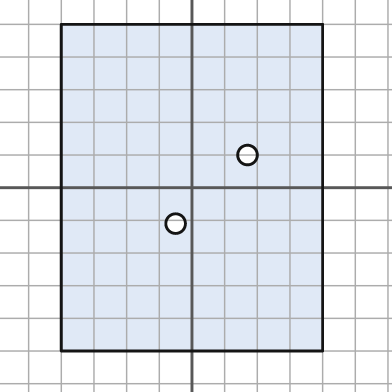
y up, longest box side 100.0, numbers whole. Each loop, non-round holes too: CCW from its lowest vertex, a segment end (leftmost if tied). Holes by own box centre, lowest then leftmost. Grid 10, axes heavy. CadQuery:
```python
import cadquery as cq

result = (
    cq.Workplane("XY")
    .moveTo(-40.0, -50.0)
    .lineTo(40.0, -50.0)
    .lineTo(40.0, 50.0)
    .lineTo(-40.0, 50.0)
    .close()
    .moveTo(-5.0, -11.0)
    .circle(3.0)
    .moveTo(17.0, 10.0)
    .circle(3.0)
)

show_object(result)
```